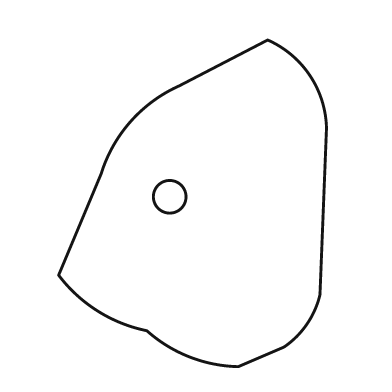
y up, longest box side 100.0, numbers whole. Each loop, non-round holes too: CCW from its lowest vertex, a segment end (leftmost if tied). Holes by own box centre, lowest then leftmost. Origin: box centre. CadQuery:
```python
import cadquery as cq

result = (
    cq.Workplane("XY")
    .moveTo(14.0, -50.0)
    .lineTo(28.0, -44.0)
    .threePointArc((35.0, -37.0), (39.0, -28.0))
    .lineTo(41.0, 23.0)
    .threePointArc((36.0, 39.0), (23.0, 50.0))
    .lineTo(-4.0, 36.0)
    .threePointArc((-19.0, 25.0), (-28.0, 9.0))
    .lineTo(-41.0, -22.0)
    .threePointArc((-29.0, -33.0), (-14.0, -39.0))
    .threePointArc((-1.0, -47.0), (14.0, -50.0))
    .close()
    .moveTo(-7.0, 2.0)
    .circle(5.0)
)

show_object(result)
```